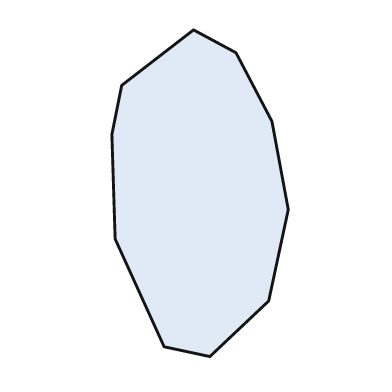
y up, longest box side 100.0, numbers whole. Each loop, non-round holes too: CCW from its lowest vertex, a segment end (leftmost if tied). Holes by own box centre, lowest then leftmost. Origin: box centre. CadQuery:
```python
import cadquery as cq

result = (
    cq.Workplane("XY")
    .moveTo(3.0, -50.0)
    .lineTo(21.0, -33.0)
    .lineTo(27.0, -5.0)
    .lineTo(22.0, 22.0)
    .lineTo(11.0, 43.0)
    .lineTo(-2.0, 50.0)
    .lineTo(-24.0, 33.0)
    .lineTo(-27.0, 18.0)
    .lineTo(-26.0, -14.0)
    .lineTo(-11.0, -47.0)
    .close()
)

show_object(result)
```